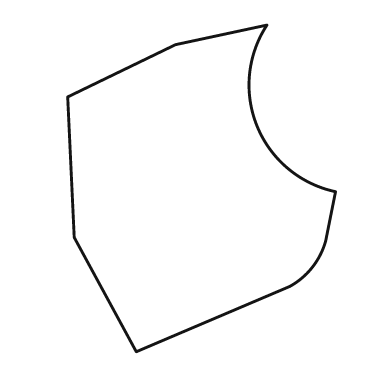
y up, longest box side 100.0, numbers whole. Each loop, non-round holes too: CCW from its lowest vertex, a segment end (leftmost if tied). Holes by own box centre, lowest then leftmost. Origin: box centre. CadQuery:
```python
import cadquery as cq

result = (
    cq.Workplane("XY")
    .moveTo(-20.0, -50.0)
    .lineTo(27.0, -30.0)
    .threePointArc((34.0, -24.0), (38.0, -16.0))
    .lineTo(41.0, -1.0)
    .threePointArc((17.0, 19.0), (20.0, 50.0))
    .lineTo(-8.0, 44.0)
    .lineTo(-41.0, 28.0)
    .lineTo(-39.0, -15.0)
    .close()
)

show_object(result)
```